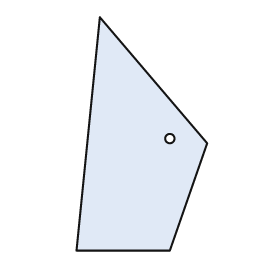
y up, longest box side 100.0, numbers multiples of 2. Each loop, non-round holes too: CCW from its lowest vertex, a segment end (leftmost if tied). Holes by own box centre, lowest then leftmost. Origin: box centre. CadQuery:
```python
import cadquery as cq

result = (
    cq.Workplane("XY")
    .moveTo(-28.0, -50.0)
    .lineTo(12.0, -50.0)
    .lineTo(28.0, -4.0)
    .lineTo(-18.0, 50.0)
    .close()
    .moveTo(12.0, -2.0)
    .circle(2.0)
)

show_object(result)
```